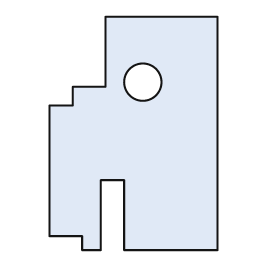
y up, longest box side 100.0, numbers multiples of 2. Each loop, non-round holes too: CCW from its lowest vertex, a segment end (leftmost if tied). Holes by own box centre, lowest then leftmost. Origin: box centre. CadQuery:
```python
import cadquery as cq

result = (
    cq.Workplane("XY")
    .moveTo(-22.0, -50.0)
    .lineTo(-14.0, -50.0)
    .lineTo(-14.0, -20.0)
    .lineTo(-4.0, -20.0)
    .lineTo(-4.0, -50.0)
    .lineTo(36.0, -50.0)
    .lineTo(36.0, 50.0)
    .lineTo(-12.0, 50.0)
    .lineTo(-12.0, 20.0)
    .lineTo(-26.0, 20.0)
    .lineTo(-26.0, 12.0)
    .lineTo(-36.0, 12.0)
    .lineTo(-36.0, -44.0)
    .lineTo(-22.0, -44.0)
    .close()
    .moveTo(4.0, 22.0)
    .circle(8.0)
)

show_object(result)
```